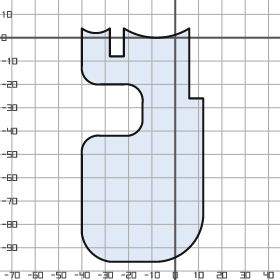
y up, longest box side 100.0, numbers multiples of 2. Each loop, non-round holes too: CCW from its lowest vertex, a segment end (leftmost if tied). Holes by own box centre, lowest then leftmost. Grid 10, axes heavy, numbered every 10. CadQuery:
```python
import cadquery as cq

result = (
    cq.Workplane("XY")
    .moveTo(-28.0, -96.0)
    .lineTo(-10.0, -96.0)
    .threePointArc((6.0, -90.0), (12.0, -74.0))
    .lineTo(12.0, -26.0)
    .lineTo(6.0, -26.0)
    .lineTo(6.0, 4.0)
    .threePointArc((-8.0, 0.0), (-22.0, 4.0))
    .lineTo(-22.0, -8.0)
    .lineTo(-28.0, -8.0)
    .lineTo(-28.0, 4.0)
    .threePointArc((-34.0, 2.0), (-40.0, 4.0))
    .lineTo(-40.0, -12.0)
    .threePointArc((-38.0, -18.0), (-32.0, -20.0))
    .lineTo(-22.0, -20.0)
    .threePointArc((-16.0, -22.0), (-14.0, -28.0))
    .lineTo(-14.0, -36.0)
    .threePointArc((-16.0, -40.0), (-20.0, -42.0))
    .lineTo(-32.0, -42.0)
    .threePointArc((-38.0, -44.0), (-40.0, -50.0))
    .lineTo(-40.0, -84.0)
    .threePointArc((-36.0, -92.0), (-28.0, -96.0))
    .close()
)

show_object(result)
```